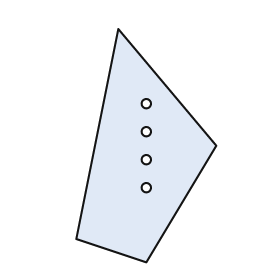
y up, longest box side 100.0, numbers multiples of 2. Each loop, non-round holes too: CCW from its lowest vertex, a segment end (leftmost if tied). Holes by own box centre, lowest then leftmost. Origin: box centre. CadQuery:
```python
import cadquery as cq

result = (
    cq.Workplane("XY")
    .moveTo(0.0, -50.0)
    .lineTo(30.0, 0.0)
    .lineTo(-12.0, 50.0)
    .lineTo(-30.0, -40.0)
    .close()
    .moveTo(0.0, -18.0)
    .circle(2.0)
    .moveTo(0.0, -6.0)
    .circle(2.0)
    .moveTo(0.0, 6.0)
    .circle(2.0)
    .moveTo(0.0, 18.0)
    .circle(2.0)
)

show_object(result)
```